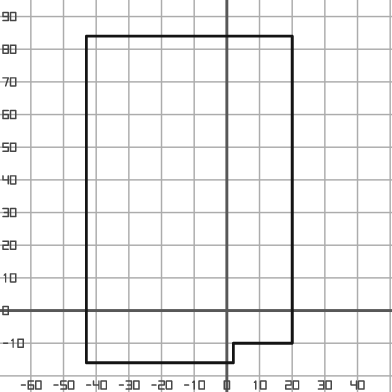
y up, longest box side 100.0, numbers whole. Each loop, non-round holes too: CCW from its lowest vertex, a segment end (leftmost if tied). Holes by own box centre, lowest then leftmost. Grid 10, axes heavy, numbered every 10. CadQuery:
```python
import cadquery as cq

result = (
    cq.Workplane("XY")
    .moveTo(-43.0, -16.0)
    .lineTo(2.0, -16.0)
    .lineTo(2.0, -10.0)
    .lineTo(20.0, -10.0)
    .lineTo(20.0, 84.0)
    .lineTo(-43.0, 84.0)
    .close()
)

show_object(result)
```